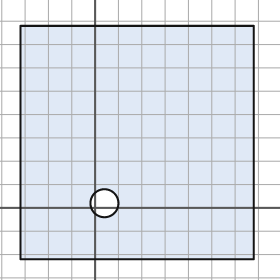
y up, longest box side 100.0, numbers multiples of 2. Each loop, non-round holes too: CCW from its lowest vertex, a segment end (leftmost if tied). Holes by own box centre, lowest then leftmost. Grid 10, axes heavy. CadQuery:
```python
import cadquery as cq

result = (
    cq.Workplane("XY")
    .moveTo(-32.0, -22.0)
    .lineTo(68.0, -22.0)
    .lineTo(68.0, 78.0)
    .lineTo(-32.0, 78.0)
    .close()
    .moveTo(4.0, 2.0)
    .circle(6.0)
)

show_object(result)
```